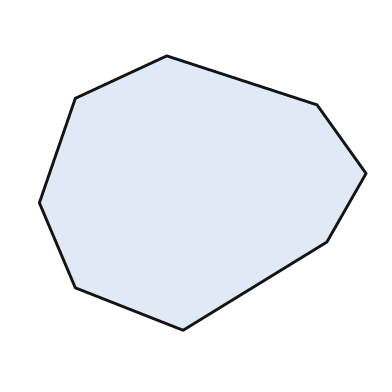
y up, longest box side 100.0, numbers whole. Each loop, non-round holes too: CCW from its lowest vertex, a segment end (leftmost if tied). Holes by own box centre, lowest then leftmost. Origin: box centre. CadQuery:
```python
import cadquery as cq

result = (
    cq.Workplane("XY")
    .moveTo(-6.0, -42.0)
    .lineTo(38.0, -15.0)
    .lineTo(50.0, 6.0)
    .lineTo(35.0, 27.0)
    .lineTo(-11.0, 42.0)
    .lineTo(-39.0, 29.0)
    .lineTo(-50.0, -3.0)
    .lineTo(-39.0, -29.0)
    .close()
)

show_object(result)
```